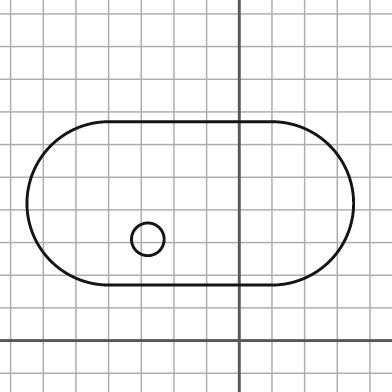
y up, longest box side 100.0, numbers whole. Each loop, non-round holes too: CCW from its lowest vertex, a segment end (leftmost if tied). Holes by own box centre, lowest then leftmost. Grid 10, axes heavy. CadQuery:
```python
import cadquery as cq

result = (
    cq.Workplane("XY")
    .moveTo(-40.0, 17.0)
    .lineTo(10.0, 17.0)
    .threePointArc((35.0, 42.0), (10.0, 67.0))
    .lineTo(-40.0, 67.0)
    .threePointArc((-65.0, 42.0), (-40.0, 17.0))
    .close()
    .moveTo(-28.0, 31.0)
    .circle(5.0)
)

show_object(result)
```